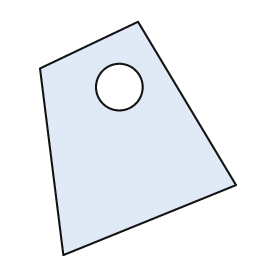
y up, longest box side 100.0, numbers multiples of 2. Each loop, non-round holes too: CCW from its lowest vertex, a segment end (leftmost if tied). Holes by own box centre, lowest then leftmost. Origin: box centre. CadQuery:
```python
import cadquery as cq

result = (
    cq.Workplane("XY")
    .moveTo(-32.0, -50.0)
    .lineTo(42.0, -20.0)
    .lineTo(0.0, 50.0)
    .lineTo(-42.0, 30.0)
    .close()
    .moveTo(-8.0, 22.0)
    .circle(10.0)
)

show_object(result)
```